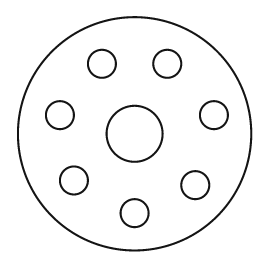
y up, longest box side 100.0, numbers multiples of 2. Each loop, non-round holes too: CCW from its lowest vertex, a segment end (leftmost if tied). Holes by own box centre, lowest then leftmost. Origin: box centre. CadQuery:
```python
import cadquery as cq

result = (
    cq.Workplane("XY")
    .moveTo(0.0, 0.0)
    .circle(50.0)
    .moveTo(0.0, -34.0)
    .circle(6.0)
    .moveTo(26.0, -22.0)
    .circle(6.0)
    .moveTo(-26.0, -20.0)
    .circle(6.0)
    .moveTo(0.0, 0.0)
    .circle(12.0)
    .moveTo(-32.0, 8.0)
    .circle(6.0)
    .moveTo(34.0, 8.0)
    .circle(6.0)
    .moveTo(-14.0, 30.0)
    .circle(6.0)
    .moveTo(14.0, 30.0)
    .circle(6.0)
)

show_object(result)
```